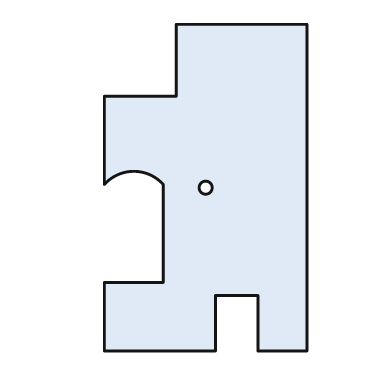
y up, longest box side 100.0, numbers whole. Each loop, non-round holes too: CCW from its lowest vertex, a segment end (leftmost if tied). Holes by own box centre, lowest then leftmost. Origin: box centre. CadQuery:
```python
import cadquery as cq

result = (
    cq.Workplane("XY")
    .moveTo(-31.0, -50.0)
    .lineTo(3.0, -50.0)
    .lineTo(3.0, -33.0)
    .lineTo(16.0, -33.0)
    .lineTo(16.0, -50.0)
    .lineTo(31.0, -50.0)
    .lineTo(31.0, 50.0)
    .lineTo(-9.0, 50.0)
    .lineTo(-9.0, 28.0)
    .lineTo(-31.0, 28.0)
    .lineTo(-31.0, 1.0)
    .threePointArc((-22.0, 5.0), (-13.0, 1.0))
    .lineTo(-13.0, -29.0)
    .lineTo(-31.0, -29.0)
    .close()
    .moveTo(0.0, 0.0)
    .circle(2.0)
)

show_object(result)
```